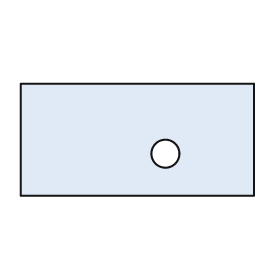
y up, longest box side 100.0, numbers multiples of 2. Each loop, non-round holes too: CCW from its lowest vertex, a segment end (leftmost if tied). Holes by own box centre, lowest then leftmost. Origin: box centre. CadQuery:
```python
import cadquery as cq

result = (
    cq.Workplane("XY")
    .moveTo(-50.0, -24.0)
    .lineTo(50.0, -24.0)
    .lineTo(50.0, 24.0)
    .lineTo(-50.0, 24.0)
    .close()
    .moveTo(12.0, -6.0)
    .circle(6.0)
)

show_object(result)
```